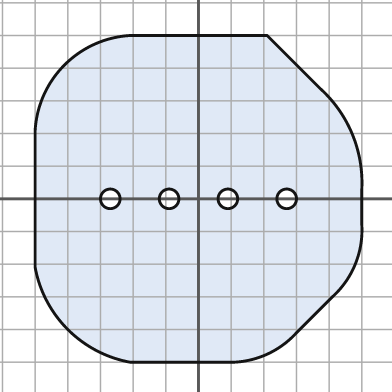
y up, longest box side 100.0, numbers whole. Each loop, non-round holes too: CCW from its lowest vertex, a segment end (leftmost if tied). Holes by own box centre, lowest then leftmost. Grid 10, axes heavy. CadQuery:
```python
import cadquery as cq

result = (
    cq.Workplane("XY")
    .moveTo(-21.0, -50.0)
    .lineTo(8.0, -50.0)
    .threePointArc((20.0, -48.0), (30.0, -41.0))
    .lineTo(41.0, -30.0)
    .threePointArc((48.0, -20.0), (50.0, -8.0))
    .lineTo(50.0, 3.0)
    .threePointArc((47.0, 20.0), (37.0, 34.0))
    .lineTo(21.0, 50.0)
    .lineTo(-21.0, 50.0)
    .threePointArc((-41.0, 41.0), (-50.0, 21.0))
    .lineTo(-50.0, -21.0)
    .threePointArc((-40.0, -40.0), (-21.0, -50.0))
    .close()
    .moveTo(-27.0, 0.0)
    .circle(3.0)
    .moveTo(-9.0, 0.0)
    .circle(3.0)
    .moveTo(9.0, 0.0)
    .circle(3.0)
    .moveTo(27.0, 0.0)
    .circle(3.0)
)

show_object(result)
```